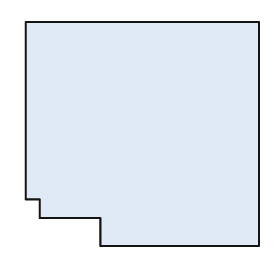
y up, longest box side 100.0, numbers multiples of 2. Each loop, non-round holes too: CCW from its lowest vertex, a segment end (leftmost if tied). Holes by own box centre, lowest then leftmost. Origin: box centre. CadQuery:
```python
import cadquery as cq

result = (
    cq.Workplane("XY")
    .moveTo(-18.0, -48.0)
    .lineTo(50.0, -48.0)
    .lineTo(50.0, 48.0)
    .lineTo(-50.0, 48.0)
    .lineTo(-50.0, -28.0)
    .lineTo(-44.0, -28.0)
    .lineTo(-44.0, -36.0)
    .lineTo(-18.0, -36.0)
    .close()
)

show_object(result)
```